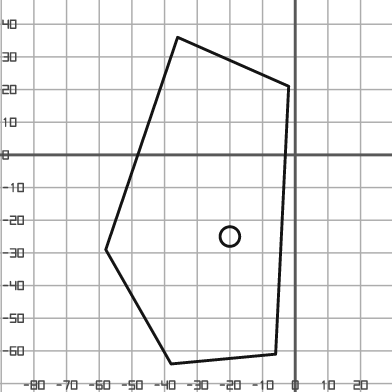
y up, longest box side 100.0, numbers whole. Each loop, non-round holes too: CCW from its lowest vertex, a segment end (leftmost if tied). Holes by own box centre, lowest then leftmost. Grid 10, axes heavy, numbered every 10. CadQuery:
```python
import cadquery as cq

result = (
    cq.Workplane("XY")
    .moveTo(-38.0, -64.0)
    .lineTo(-6.0, -61.0)
    .lineTo(-2.0, 21.0)
    .lineTo(-36.0, 36.0)
    .lineTo(-58.0, -29.0)
    .close()
    .moveTo(-20.0, -25.0)
    .circle(3.0)
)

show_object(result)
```